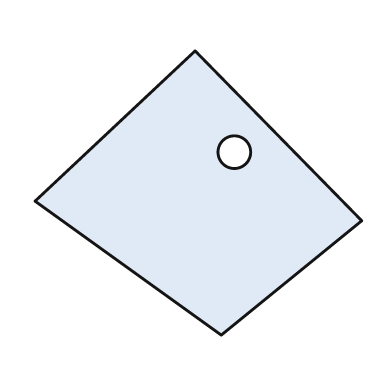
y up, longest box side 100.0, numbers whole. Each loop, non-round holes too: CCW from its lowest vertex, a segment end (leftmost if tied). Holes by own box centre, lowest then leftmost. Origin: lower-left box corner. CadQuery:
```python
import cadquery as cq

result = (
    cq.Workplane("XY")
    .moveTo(57.0, 0.0)
    .lineTo(100.0, 35.0)
    .lineTo(49.0, 87.0)
    .lineTo(0.0, 41.0)
    .close()
    .moveTo(61.0, 56.0)
    .circle(5.0)
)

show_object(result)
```